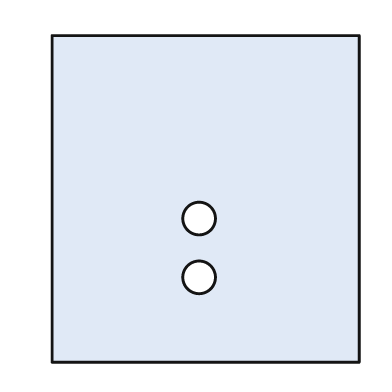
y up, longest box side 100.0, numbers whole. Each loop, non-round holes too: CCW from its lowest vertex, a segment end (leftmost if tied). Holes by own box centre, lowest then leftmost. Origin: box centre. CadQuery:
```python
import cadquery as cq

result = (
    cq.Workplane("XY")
    .moveTo(-47.0, -50.0)
    .lineTo(47.0, -50.0)
    .lineTo(47.0, 50.0)
    .lineTo(-47.0, 50.0)
    .close()
    .moveTo(-2.0, -24.0)
    .circle(5.0)
    .moveTo(-2.0, -6.0)
    .circle(5.0)
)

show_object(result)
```